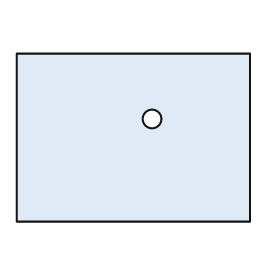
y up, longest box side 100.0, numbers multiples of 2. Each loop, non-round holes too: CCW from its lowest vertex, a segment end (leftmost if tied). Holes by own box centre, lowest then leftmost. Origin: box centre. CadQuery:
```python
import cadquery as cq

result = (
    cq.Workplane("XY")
    .moveTo(-50.0, -36.0)
    .lineTo(50.0, -36.0)
    .lineTo(50.0, 36.0)
    .lineTo(-50.0, 36.0)
    .close()
    .moveTo(8.0, 8.0)
    .circle(4.0)
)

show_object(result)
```